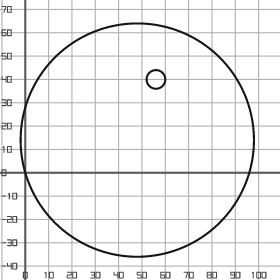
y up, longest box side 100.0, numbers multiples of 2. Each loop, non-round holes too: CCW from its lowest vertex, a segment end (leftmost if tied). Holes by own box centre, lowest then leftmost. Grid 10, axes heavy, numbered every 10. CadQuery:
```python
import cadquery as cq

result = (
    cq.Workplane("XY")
    .moveTo(48.0, 14.0)
    .circle(50.0)
    .moveTo(56.0, 40.0)
    .circle(4.0)
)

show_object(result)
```